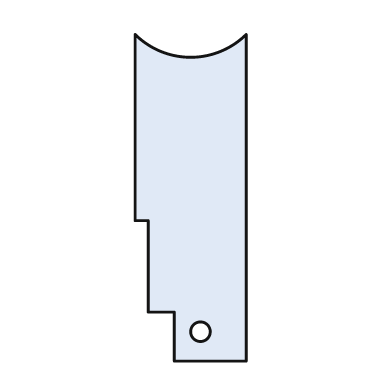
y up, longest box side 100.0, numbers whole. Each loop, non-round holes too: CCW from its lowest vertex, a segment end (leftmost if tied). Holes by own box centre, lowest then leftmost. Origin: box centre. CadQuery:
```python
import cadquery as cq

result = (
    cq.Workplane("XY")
    .moveTo(-5.0, -50.0)
    .lineTo(17.0, -50.0)
    .lineTo(17.0, 50.0)
    .threePointArc((0.0, 43.0), (-17.0, 50.0))
    .lineTo(-17.0, -7.0)
    .lineTo(-13.0, -7.0)
    .lineTo(-13.0, -35.0)
    .lineTo(-5.0, -35.0)
    .close()
    .moveTo(3.0, -41.0)
    .circle(3.0)
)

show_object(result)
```